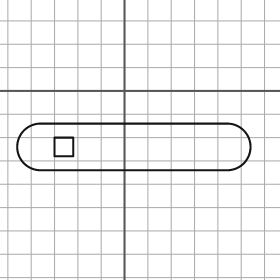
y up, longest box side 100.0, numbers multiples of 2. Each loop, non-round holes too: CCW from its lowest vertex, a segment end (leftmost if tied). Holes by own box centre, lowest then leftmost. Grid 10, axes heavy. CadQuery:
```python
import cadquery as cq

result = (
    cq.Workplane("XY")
    .moveTo(-36.0, -34.0)
    .lineTo(44.0, -34.0)
    .threePointArc((54.0, -24.0), (44.0, -14.0))
    .lineTo(-36.0, -14.0)
    .threePointArc((-46.0, -24.0), (-36.0, -34.0))
    .close()
    .moveTo(-30.0, -28.0)
    .lineTo(-22.0, -28.0)
    .lineTo(-22.0, -20.0)
    .lineTo(-30.0, -20.0)
    .close()
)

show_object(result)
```